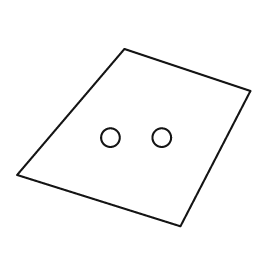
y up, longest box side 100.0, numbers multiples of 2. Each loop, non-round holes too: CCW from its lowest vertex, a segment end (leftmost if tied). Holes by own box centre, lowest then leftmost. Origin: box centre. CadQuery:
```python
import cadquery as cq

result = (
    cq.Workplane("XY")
    .moveTo(20.0, -38.0)
    .lineTo(50.0, 20.0)
    .lineTo(-4.0, 38.0)
    .lineTo(-50.0, -16.0)
    .close()
    .moveTo(-10.0, 0.0)
    .circle(4.0)
    .moveTo(12.0, 0.0)
    .circle(4.0)
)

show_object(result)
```